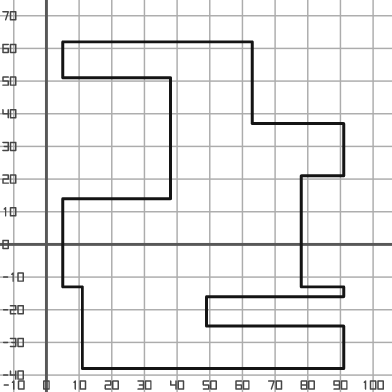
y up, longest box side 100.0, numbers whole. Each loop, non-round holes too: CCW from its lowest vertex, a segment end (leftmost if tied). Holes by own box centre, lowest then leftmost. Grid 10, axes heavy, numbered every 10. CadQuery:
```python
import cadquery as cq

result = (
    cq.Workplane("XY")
    .moveTo(11.0, -38.0)
    .lineTo(91.0, -38.0)
    .lineTo(91.0, -25.0)
    .lineTo(49.0, -25.0)
    .lineTo(49.0, -16.0)
    .lineTo(91.0, -16.0)
    .lineTo(91.0, -13.0)
    .lineTo(78.0, -13.0)
    .lineTo(78.0, 21.0)
    .lineTo(91.0, 21.0)
    .lineTo(91.0, 37.0)
    .lineTo(63.0, 37.0)
    .lineTo(63.0, 62.0)
    .lineTo(5.0, 62.0)
    .lineTo(5.0, 51.0)
    .lineTo(38.0, 51.0)
    .lineTo(38.0, 14.0)
    .lineTo(5.0, 14.0)
    .lineTo(5.0, -13.0)
    .lineTo(11.0, -13.0)
    .close()
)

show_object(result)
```